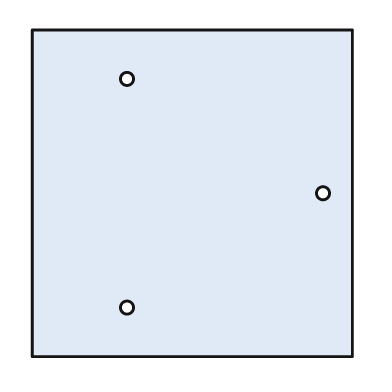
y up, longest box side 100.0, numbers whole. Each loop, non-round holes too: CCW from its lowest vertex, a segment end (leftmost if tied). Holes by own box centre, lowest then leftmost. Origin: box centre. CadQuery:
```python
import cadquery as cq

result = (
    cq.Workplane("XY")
    .moveTo(-49.0, -50.0)
    .lineTo(49.0, -50.0)
    .lineTo(49.0, 50.0)
    .lineTo(-49.0, 50.0)
    .close()
    .moveTo(-20.0, -35.0)
    .circle(2.0)
    .moveTo(40.0, 0.0)
    .circle(2.0)
    .moveTo(-20.0, 35.0)
    .circle(2.0)
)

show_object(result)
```